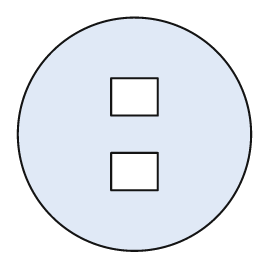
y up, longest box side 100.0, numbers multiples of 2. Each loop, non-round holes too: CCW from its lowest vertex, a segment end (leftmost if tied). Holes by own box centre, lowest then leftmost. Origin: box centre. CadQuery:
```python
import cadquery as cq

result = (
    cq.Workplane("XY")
    .moveTo(0.0, 0.0)
    .circle(50.0)
    .moveTo(-10.0, -24.0)
    .lineTo(10.0, -24.0)
    .lineTo(10.0, -8.0)
    .lineTo(-10.0, -8.0)
    .close()
    .moveTo(-10.0, 8.0)
    .lineTo(10.0, 8.0)
    .lineTo(10.0, 24.0)
    .lineTo(-10.0, 24.0)
    .close()
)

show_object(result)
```